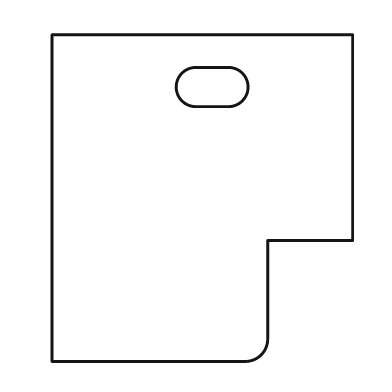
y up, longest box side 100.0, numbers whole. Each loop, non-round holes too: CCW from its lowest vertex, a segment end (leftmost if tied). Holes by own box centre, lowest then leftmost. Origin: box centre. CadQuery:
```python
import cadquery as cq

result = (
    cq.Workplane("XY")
    .moveTo(-46.0, -50.0)
    .lineTo(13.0, -50.0)
    .threePointArc((18.0, -48.0), (20.0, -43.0))
    .lineTo(20.0, -13.0)
    .lineTo(46.0, -13.0)
    .lineTo(46.0, 50.0)
    .lineTo(-46.0, 50.0)
    .close()
    .moveTo(-2.0, 28.0)
    .lineTo(8.0, 28.0)
    .threePointArc((14.0, 34.0), (8.0, 40.0))
    .lineTo(-2.0, 40.0)
    .threePointArc((-8.0, 34.0), (-2.0, 28.0))
    .close()
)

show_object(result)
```